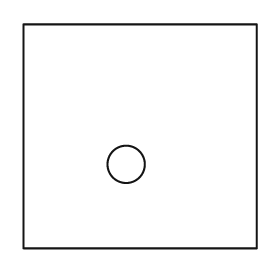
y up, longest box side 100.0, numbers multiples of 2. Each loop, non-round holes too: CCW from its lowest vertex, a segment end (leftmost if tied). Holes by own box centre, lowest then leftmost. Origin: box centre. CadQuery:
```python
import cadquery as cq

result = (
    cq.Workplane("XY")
    .moveTo(-50.0, -48.0)
    .lineTo(50.0, -48.0)
    .lineTo(50.0, 48.0)
    .lineTo(-50.0, 48.0)
    .close()
    .moveTo(-6.0, -12.0)
    .circle(8.0)
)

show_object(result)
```